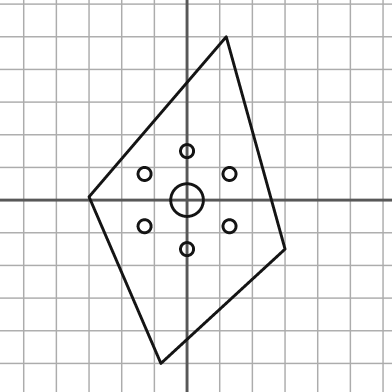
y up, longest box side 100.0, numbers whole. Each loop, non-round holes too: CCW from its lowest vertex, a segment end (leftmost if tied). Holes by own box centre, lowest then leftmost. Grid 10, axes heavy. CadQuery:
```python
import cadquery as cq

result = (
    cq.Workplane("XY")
    .moveTo(-8.0, -50.0)
    .lineTo(30.0, -15.0)
    .lineTo(12.0, 50.0)
    .lineTo(-30.0, 1.0)
    .close()
    .moveTo(0.0, -15.0)
    .circle(2.0)
    .moveTo(-13.0, -8.0)
    .circle(2.0)
    .moveTo(13.0, -8.0)
    .circle(2.0)
    .moveTo(0.0, 0.0)
    .circle(5.0)
    .moveTo(-13.0, 8.0)
    .circle(2.0)
    .moveTo(13.0, 8.0)
    .circle(2.0)
    .moveTo(0.0, 15.0)
    .circle(2.0)
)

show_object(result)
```